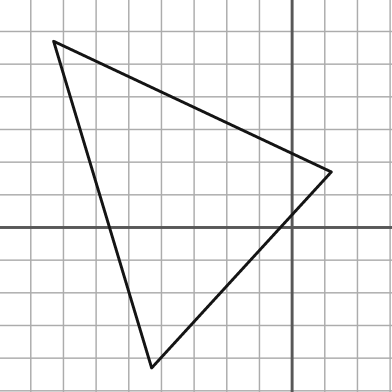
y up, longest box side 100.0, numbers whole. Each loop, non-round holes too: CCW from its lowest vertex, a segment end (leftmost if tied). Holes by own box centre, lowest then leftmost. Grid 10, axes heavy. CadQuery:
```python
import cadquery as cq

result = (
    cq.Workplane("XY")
    .moveTo(-43.0, -43.0)
    .lineTo(12.0, 17.0)
    .lineTo(-73.0, 57.0)
    .close()
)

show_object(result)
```